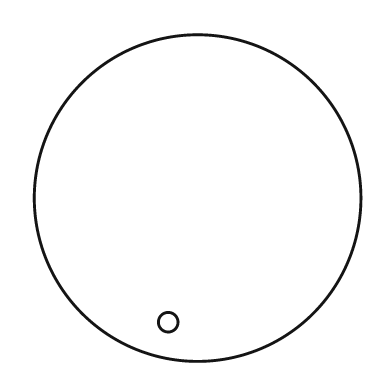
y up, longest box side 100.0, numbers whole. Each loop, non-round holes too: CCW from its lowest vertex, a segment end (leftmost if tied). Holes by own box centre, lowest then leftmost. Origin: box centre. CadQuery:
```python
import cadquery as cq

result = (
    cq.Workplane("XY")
    .moveTo(0.0, 0.0)
    .circle(50.0)
    .moveTo(-9.0, -38.0)
    .circle(3.0)
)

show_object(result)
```